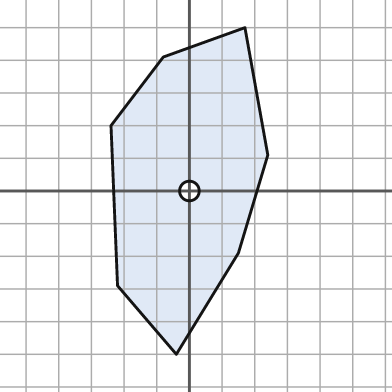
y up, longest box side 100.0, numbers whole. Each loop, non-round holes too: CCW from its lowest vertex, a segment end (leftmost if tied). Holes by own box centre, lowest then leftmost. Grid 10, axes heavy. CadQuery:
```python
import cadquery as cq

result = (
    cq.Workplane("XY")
    .moveTo(-4.0, -50.0)
    .lineTo(15.0, -19.0)
    .lineTo(24.0, 11.0)
    .lineTo(17.0, 50.0)
    .lineTo(-8.0, 41.0)
    .lineTo(-24.0, 20.0)
    .lineTo(-22.0, -29.0)
    .close()
    .moveTo(0.0, 0.0)
    .circle(3.0)
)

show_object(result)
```